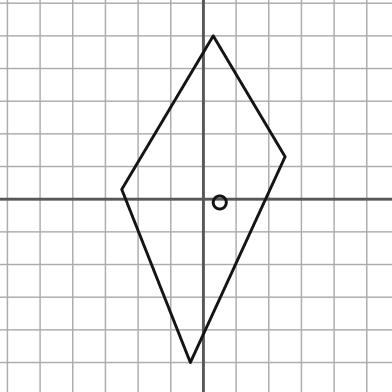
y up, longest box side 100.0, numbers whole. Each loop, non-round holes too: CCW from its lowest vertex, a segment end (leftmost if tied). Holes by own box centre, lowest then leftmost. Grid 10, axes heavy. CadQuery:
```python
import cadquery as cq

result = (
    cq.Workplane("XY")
    .moveTo(-4.0, -50.0)
    .lineTo(25.0, 13.0)
    .lineTo(3.0, 50.0)
    .lineTo(-25.0, 3.0)
    .close()
    .moveTo(5.0, -1.0)
    .circle(2.0)
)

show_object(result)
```